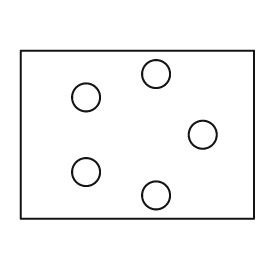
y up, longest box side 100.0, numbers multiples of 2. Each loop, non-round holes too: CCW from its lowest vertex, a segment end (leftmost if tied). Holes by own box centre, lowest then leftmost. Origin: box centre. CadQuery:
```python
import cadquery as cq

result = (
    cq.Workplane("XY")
    .moveTo(-50.0, -36.0)
    .lineTo(50.0, -36.0)
    .lineTo(50.0, 36.0)
    .lineTo(-50.0, 36.0)
    .close()
    .moveTo(8.0, -26.0)
    .circle(6.0)
    .moveTo(-22.0, -16.0)
    .circle(6.0)
    .moveTo(28.0, 0.0)
    .circle(6.0)
    .moveTo(-22.0, 16.0)
    .circle(6.0)
    .moveTo(8.0, 26.0)
    .circle(6.0)
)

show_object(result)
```